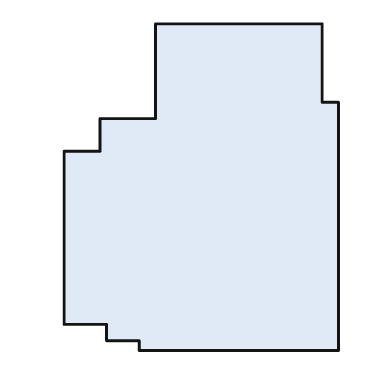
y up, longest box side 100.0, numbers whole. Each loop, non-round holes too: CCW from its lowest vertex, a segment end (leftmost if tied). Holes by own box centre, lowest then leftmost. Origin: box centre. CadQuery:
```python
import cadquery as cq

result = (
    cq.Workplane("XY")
    .moveTo(-19.0, -50.0)
    .lineTo(42.0, -50.0)
    .lineTo(42.0, 26.0)
    .lineTo(37.0, 26.0)
    .lineTo(37.0, 50.0)
    .lineTo(-14.0, 50.0)
    .lineTo(-14.0, 21.0)
    .lineTo(-31.0, 21.0)
    .lineTo(-31.0, 11.0)
    .lineTo(-42.0, 11.0)
    .lineTo(-42.0, -42.0)
    .lineTo(-29.0, -42.0)
    .lineTo(-29.0, -47.0)
    .lineTo(-19.0, -47.0)
    .close()
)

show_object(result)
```